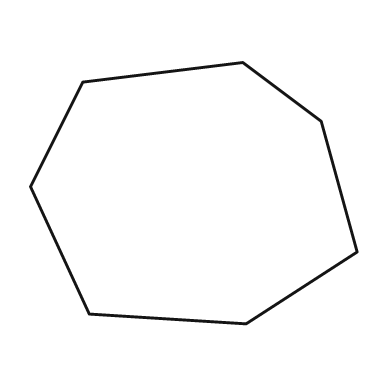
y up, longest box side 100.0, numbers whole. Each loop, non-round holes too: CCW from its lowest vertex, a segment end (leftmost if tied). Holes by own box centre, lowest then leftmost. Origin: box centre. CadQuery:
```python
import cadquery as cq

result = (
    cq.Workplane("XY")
    .moveTo(16.0, -40.0)
    .lineTo(50.0, -18.0)
    .lineTo(39.0, 22.0)
    .lineTo(15.0, 40.0)
    .lineTo(-34.0, 34.0)
    .lineTo(-50.0, 2.0)
    .lineTo(-32.0, -37.0)
    .close()
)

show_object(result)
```